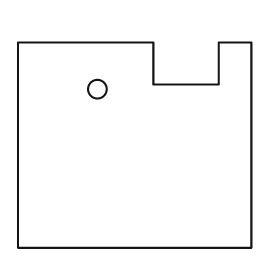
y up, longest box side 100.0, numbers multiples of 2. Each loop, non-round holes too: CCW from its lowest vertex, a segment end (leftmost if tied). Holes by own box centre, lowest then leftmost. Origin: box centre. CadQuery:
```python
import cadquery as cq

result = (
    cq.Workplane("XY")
    .moveTo(-50.0, -44.0)
    .lineTo(50.0, -44.0)
    .lineTo(50.0, 44.0)
    .lineTo(36.0, 44.0)
    .lineTo(36.0, 26.0)
    .lineTo(8.0, 26.0)
    .lineTo(8.0, 44.0)
    .lineTo(-50.0, 44.0)
    .close()
    .moveTo(-16.0, 24.0)
    .circle(4.0)
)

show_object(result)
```